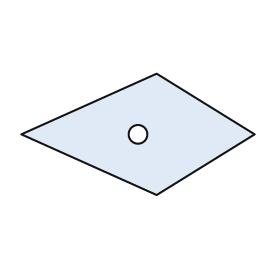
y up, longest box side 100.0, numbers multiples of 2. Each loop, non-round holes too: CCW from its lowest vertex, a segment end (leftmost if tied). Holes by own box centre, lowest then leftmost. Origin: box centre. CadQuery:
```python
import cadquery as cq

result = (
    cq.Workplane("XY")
    .moveTo(8.0, -26.0)
    .lineTo(50.0, 0.0)
    .lineTo(8.0, 26.0)
    .lineTo(-50.0, 0.0)
    .close()
    .moveTo(0.0, 0.0)
    .circle(4.0)
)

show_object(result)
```